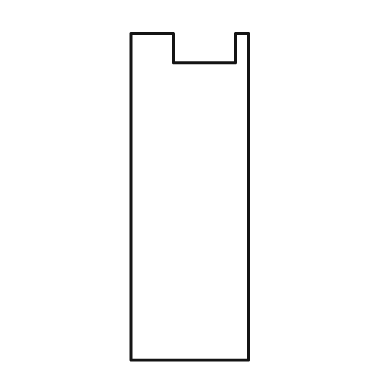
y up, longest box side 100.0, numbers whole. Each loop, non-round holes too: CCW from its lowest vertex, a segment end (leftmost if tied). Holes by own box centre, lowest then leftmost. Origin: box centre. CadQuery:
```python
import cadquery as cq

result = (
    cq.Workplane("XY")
    .moveTo(-18.0, -50.0)
    .lineTo(18.0, -50.0)
    .lineTo(18.0, 50.0)
    .lineTo(14.0, 50.0)
    .lineTo(14.0, 41.0)
    .lineTo(-5.0, 41.0)
    .lineTo(-5.0, 50.0)
    .lineTo(-18.0, 50.0)
    .close()
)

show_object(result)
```